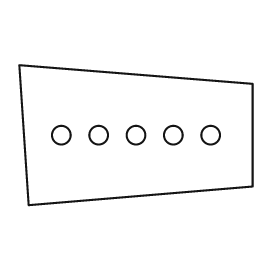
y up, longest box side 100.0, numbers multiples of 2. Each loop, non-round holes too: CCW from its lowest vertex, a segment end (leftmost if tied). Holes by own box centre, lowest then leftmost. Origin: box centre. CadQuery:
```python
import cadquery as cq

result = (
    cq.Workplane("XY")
    .moveTo(-46.0, -30.0)
    .lineTo(50.0, -22.0)
    .lineTo(50.0, 22.0)
    .lineTo(-50.0, 30.0)
    .close()
    .moveTo(-32.0, 0.0)
    .circle(4.0)
    .moveTo(-16.0, 0.0)
    .circle(4.0)
    .moveTo(0.0, 0.0)
    .circle(4.0)
    .moveTo(16.0, 0.0)
    .circle(4.0)
    .moveTo(32.0, 0.0)
    .circle(4.0)
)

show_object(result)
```